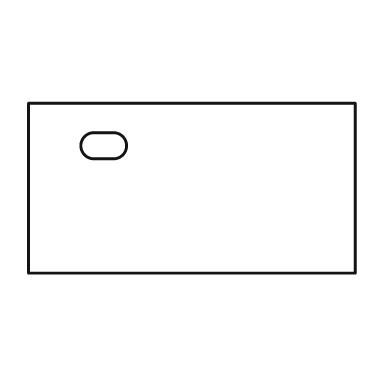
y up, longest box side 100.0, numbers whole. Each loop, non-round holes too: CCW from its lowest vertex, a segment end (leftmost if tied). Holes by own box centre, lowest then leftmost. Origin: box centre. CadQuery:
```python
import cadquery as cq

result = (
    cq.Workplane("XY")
    .moveTo(-50.0, -26.0)
    .lineTo(50.0, -26.0)
    .lineTo(50.0, 26.0)
    .lineTo(-50.0, 26.0)
    .close()
    .moveTo(-30.0, 9.0)
    .lineTo(-24.0, 9.0)
    .threePointArc((-20.0, 13.0), (-24.0, 17.0))
    .lineTo(-30.0, 17.0)
    .threePointArc((-34.0, 13.0), (-30.0, 9.0))
    .close()
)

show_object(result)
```